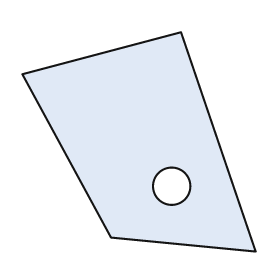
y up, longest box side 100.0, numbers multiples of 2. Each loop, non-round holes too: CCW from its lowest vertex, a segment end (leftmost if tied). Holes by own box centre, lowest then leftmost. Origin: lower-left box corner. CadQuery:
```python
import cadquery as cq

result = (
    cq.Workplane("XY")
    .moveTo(100.0, 0.0)
    .lineTo(68.0, 94.0)
    .lineTo(0.0, 76.0)
    .lineTo(38.0, 6.0)
    .close()
    .moveTo(64.0, 28.0)
    .circle(8.0)
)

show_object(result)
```